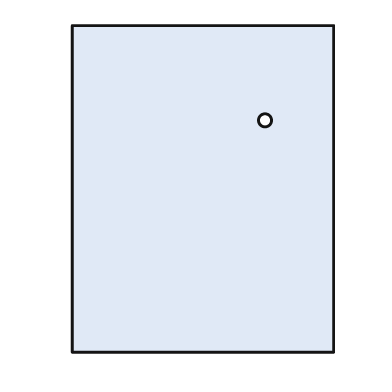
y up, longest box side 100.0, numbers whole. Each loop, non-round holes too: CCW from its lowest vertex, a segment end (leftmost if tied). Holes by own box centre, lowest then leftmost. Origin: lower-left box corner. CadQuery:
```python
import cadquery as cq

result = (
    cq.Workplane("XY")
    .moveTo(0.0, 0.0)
    .lineTo(80.0, 0.0)
    .lineTo(80.0, 100.0)
    .lineTo(0.0, 100.0)
    .close()
    .moveTo(59.0, 71.0)
    .circle(2.0)
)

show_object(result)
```